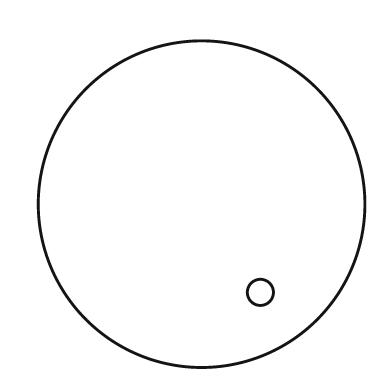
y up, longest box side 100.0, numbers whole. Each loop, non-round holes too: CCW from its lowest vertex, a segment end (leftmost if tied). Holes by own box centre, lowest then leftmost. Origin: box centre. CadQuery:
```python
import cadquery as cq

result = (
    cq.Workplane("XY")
    .moveTo(0.0, 0.0)
    .circle(50.0)
    .moveTo(18.0, -27.0)
    .circle(4.0)
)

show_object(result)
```